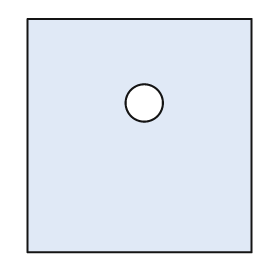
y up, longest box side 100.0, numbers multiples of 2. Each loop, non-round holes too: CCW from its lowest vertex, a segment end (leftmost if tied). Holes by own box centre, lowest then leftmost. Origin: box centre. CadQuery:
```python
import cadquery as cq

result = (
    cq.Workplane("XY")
    .moveTo(-48.0, -50.0)
    .lineTo(48.0, -50.0)
    .lineTo(48.0, 50.0)
    .lineTo(-48.0, 50.0)
    .close()
    .moveTo(2.0, 14.0)
    .circle(8.0)
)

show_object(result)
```